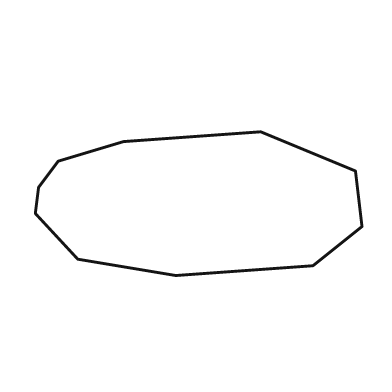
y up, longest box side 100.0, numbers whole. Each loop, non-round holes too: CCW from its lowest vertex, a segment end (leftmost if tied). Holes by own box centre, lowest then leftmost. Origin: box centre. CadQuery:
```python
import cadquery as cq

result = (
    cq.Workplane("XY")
    .moveTo(-7.0, -22.0)
    .lineTo(35.0, -19.0)
    .lineTo(50.0, -7.0)
    .lineTo(48.0, 10.0)
    .lineTo(19.0, 22.0)
    .lineTo(-23.0, 19.0)
    .lineTo(-43.0, 13.0)
    .lineTo(-49.0, 5.0)
    .lineTo(-50.0, -3.0)
    .lineTo(-37.0, -17.0)
    .close()
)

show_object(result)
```